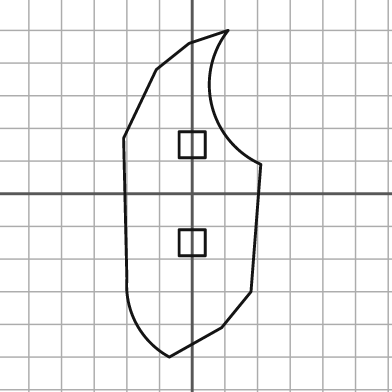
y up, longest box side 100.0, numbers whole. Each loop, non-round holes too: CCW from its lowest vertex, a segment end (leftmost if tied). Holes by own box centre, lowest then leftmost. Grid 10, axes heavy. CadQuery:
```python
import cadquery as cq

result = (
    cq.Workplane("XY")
    .moveTo(-7.0, -50.0)
    .lineTo(9.0, -41.0)
    .lineTo(18.0, -30.0)
    .lineTo(21.0, 9.0)
    .threePointArc((6.0, 27.0), (11.0, 50.0))
    .lineTo(-1.0, 46.0)
    .lineTo(-11.0, 38.0)
    .lineTo(-21.0, 17.0)
    .lineTo(-20.0, -26.0)
    .threePointArc((-17.0, -40.0), (-7.0, -50.0))
    .close()
    .moveTo(-4.0, -19.0)
    .lineTo(4.0, -19.0)
    .lineTo(4.0, -11.0)
    .lineTo(-4.0, -11.0)
    .close()
    .moveTo(-4.0, 11.0)
    .lineTo(4.0, 11.0)
    .lineTo(4.0, 19.0)
    .lineTo(-4.0, 19.0)
    .close()
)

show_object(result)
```